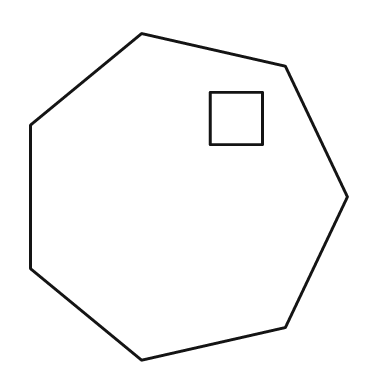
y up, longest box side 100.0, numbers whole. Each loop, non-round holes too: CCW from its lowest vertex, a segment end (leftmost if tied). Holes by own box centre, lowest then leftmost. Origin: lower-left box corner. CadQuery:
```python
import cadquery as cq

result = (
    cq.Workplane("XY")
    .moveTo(34.0, 0.0)
    .lineTo(78.0, 10.0)
    .lineTo(97.0, 50.0)
    .lineTo(78.0, 90.0)
    .lineTo(34.0, 100.0)
    .lineTo(0.0, 72.0)
    .lineTo(0.0, 28.0)
    .close()
    .moveTo(55.0, 66.0)
    .lineTo(71.0, 66.0)
    .lineTo(71.0, 82.0)
    .lineTo(55.0, 82.0)
    .close()
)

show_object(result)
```